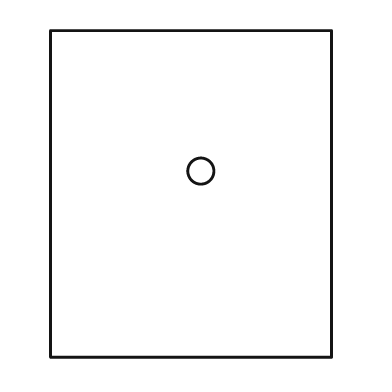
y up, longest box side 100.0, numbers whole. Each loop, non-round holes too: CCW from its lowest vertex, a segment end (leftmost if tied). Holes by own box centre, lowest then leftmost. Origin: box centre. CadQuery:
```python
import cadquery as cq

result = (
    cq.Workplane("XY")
    .moveTo(-43.0, -50.0)
    .lineTo(43.0, -50.0)
    .lineTo(43.0, 50.0)
    .lineTo(-43.0, 50.0)
    .close()
    .moveTo(3.0, 7.0)
    .circle(4.0)
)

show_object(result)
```